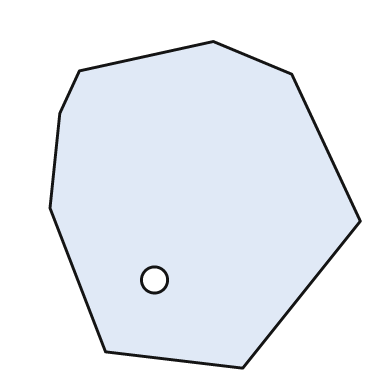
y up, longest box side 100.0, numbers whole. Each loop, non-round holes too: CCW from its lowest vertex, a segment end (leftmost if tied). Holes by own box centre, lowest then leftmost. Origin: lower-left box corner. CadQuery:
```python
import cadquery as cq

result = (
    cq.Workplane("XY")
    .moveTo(59.0, 0.0)
    .lineTo(95.0, 45.0)
    .lineTo(74.0, 90.0)
    .lineTo(50.0, 100.0)
    .lineTo(9.0, 91.0)
    .lineTo(3.0, 78.0)
    .lineTo(0.0, 49.0)
    .lineTo(17.0, 5.0)
    .close()
    .moveTo(32.0, 27.0)
    .circle(4.0)
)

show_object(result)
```